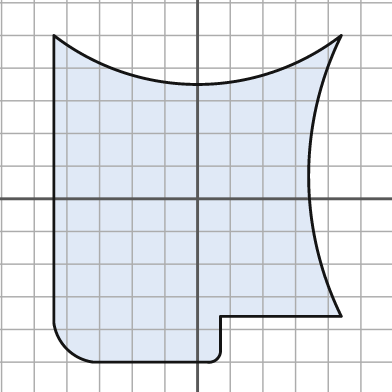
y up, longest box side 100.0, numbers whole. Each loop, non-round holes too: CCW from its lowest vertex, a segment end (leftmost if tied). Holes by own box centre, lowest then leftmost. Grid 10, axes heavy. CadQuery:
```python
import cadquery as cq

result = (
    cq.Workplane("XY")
    .moveTo(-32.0, -50.0)
    .lineTo(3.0, -50.0)
    .threePointArc((6.0, -49.0), (7.0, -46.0))
    .lineTo(7.0, -36.0)
    .lineTo(44.0, -36.0)
    .threePointArc((34.0, 7.0), (44.0, 50.0))
    .threePointArc((0.0, 35.0), (-44.0, 50.0))
    .lineTo(-44.0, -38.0)
    .threePointArc((-40.0, -46.0), (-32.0, -50.0))
    .close()
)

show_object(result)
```